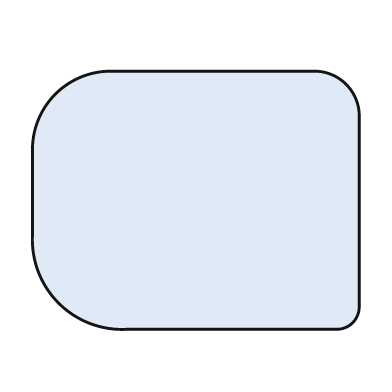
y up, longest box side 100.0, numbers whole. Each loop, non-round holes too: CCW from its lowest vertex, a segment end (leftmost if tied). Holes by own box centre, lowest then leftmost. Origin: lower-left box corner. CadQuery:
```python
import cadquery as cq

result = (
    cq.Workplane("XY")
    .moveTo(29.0, 0.0)
    .lineTo(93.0, 0.0)
    .threePointArc((98.0, 2.0), (100.0, 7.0))
    .lineTo(100.0, 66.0)
    .threePointArc((96.0, 75.0), (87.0, 79.0))
    .lineTo(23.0, 79.0)
    .threePointArc((7.0, 72.0), (0.0, 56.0))
    .lineTo(0.0, 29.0)
    .threePointArc((8.0, 8.0), (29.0, 0.0))
    .close()
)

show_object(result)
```